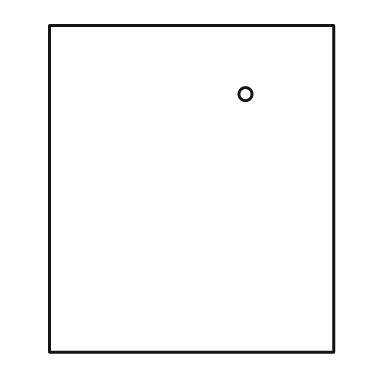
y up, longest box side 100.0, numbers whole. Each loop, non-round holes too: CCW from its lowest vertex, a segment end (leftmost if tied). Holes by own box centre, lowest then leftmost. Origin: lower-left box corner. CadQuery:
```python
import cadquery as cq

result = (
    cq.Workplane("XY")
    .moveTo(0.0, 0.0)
    .lineTo(87.0, 0.0)
    .lineTo(87.0, 100.0)
    .lineTo(0.0, 100.0)
    .close()
    .moveTo(60.0, 79.0)
    .circle(2.0)
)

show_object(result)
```